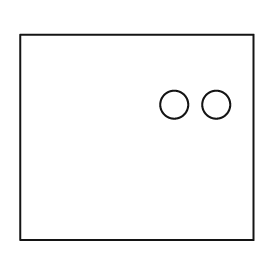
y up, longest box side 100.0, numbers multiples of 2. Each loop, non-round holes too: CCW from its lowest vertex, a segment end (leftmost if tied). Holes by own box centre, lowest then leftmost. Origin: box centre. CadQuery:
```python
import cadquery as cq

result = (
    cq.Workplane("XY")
    .moveTo(-50.0, -44.0)
    .lineTo(50.0, -44.0)
    .lineTo(50.0, 44.0)
    .lineTo(-50.0, 44.0)
    .close()
    .moveTo(16.0, 14.0)
    .circle(6.0)
    .moveTo(34.0, 14.0)
    .circle(6.0)
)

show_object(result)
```